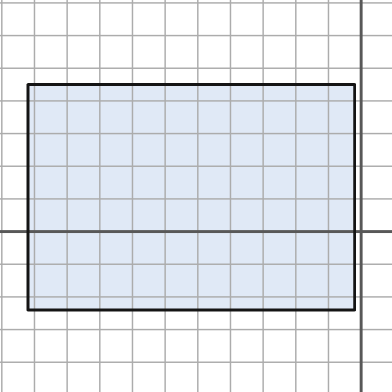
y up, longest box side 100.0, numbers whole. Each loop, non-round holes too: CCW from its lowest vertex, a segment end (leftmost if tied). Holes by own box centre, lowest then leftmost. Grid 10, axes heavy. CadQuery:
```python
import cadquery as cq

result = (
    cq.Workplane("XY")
    .moveTo(-102.0, -24.0)
    .lineTo(-2.0, -24.0)
    .lineTo(-2.0, 45.0)
    .lineTo(-102.0, 45.0)
    .close()
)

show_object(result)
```